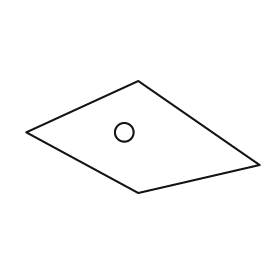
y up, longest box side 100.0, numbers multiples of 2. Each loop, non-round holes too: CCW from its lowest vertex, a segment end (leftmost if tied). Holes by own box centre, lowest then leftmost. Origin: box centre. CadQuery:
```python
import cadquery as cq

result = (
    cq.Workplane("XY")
    .moveTo(-2.0, -24.0)
    .lineTo(50.0, -12.0)
    .lineTo(-2.0, 24.0)
    .lineTo(-50.0, 2.0)
    .close()
    .moveTo(-8.0, 2.0)
    .circle(4.0)
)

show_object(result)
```